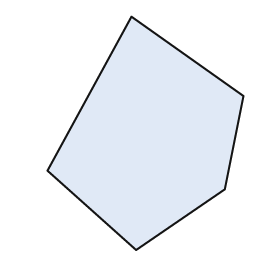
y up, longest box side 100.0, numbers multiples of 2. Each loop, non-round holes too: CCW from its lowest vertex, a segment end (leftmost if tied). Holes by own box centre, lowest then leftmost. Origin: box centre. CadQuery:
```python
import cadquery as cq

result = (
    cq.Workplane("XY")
    .moveTo(-4.0, -50.0)
    .lineTo(34.0, -24.0)
    .lineTo(42.0, 16.0)
    .lineTo(-6.0, 50.0)
    .lineTo(-42.0, -16.0)
    .close()
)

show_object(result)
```